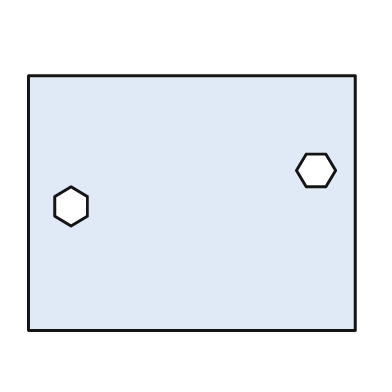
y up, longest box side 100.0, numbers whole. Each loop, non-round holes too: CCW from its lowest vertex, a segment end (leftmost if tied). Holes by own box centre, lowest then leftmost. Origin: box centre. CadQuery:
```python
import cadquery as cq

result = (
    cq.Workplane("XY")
    .moveTo(-50.0, -39.0)
    .lineTo(50.0, -39.0)
    .lineTo(50.0, 39.0)
    .lineTo(-50.0, 39.0)
    .close()
    .moveTo(-37.0, -7.0)
    .lineTo(-32.0, -4.0)
    .lineTo(-32.0, 2.0)
    .lineTo(-37.0, 5.0)
    .lineTo(-42.0, 2.0)
    .lineTo(-42.0, -4.0)
    .close()
    .moveTo(35.0, 5.0)
    .lineTo(41.0, 5.0)
    .lineTo(44.0, 10.0)
    .lineTo(41.0, 15.0)
    .lineTo(35.0, 15.0)
    .lineTo(32.0, 10.0)
    .close()
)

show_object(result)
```